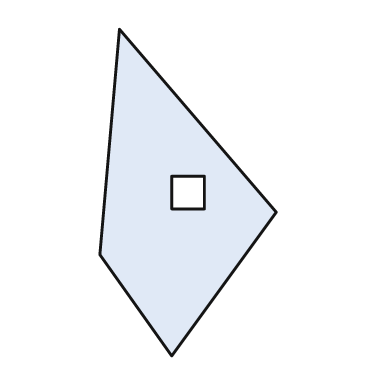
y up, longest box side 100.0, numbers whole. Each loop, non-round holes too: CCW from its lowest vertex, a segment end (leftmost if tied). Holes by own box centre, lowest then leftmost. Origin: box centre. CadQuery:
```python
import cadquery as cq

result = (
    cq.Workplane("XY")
    .moveTo(-5.0, -50.0)
    .lineTo(27.0, -6.0)
    .lineTo(-21.0, 50.0)
    .lineTo(-27.0, -19.0)
    .close()
    .moveTo(-5.0, -5.0)
    .lineTo(5.0, -5.0)
    .lineTo(5.0, 5.0)
    .lineTo(-5.0, 5.0)
    .close()
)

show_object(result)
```